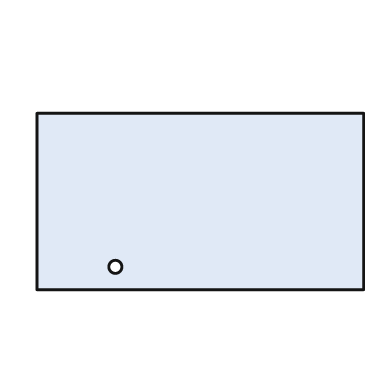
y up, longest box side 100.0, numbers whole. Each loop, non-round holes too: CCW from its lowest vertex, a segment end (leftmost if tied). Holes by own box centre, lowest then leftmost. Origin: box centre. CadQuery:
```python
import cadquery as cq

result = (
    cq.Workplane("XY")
    .moveTo(-50.0, -27.0)
    .lineTo(50.0, -27.0)
    .lineTo(50.0, 27.0)
    .lineTo(-50.0, 27.0)
    .close()
    .moveTo(-26.0, -20.0)
    .circle(2.0)
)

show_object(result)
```